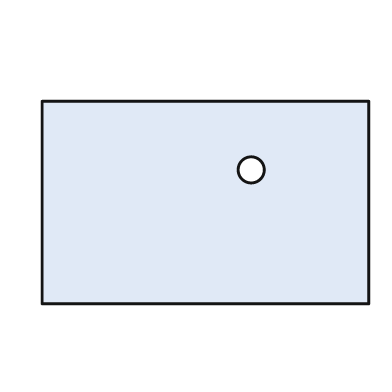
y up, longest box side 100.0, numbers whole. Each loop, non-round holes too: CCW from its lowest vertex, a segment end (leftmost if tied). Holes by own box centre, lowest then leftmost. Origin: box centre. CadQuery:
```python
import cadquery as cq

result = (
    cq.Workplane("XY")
    .moveTo(-50.0, -31.0)
    .lineTo(50.0, -31.0)
    .lineTo(50.0, 31.0)
    .lineTo(-50.0, 31.0)
    .close()
    .moveTo(14.0, 10.0)
    .circle(4.0)
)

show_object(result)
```